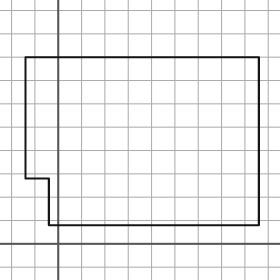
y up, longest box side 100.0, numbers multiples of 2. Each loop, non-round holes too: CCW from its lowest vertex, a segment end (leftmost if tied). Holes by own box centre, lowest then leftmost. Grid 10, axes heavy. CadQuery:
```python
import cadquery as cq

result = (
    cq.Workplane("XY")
    .moveTo(-4.0, 8.0)
    .lineTo(86.0, 8.0)
    .lineTo(86.0, 80.0)
    .lineTo(-14.0, 80.0)
    .lineTo(-14.0, 28.0)
    .lineTo(-4.0, 28.0)
    .close()
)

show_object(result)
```